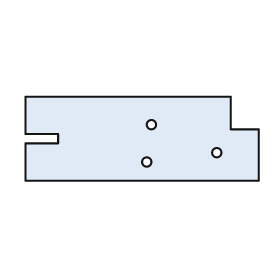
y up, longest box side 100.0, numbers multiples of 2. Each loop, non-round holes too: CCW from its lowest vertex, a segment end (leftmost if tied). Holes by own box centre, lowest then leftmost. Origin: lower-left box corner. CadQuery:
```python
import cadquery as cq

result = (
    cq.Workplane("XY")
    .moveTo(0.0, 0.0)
    .lineTo(100.0, 0.0)
    .lineTo(100.0, 22.0)
    .lineTo(88.0, 22.0)
    .lineTo(88.0, 36.0)
    .lineTo(0.0, 36.0)
    .lineTo(0.0, 20.0)
    .lineTo(14.0, 20.0)
    .lineTo(14.0, 16.0)
    .lineTo(0.0, 16.0)
    .close()
    .moveTo(52.0, 8.0)
    .circle(2.0)
    .moveTo(82.0, 12.0)
    .circle(2.0)
    .moveTo(54.0, 24.0)
    .circle(2.0)
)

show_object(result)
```